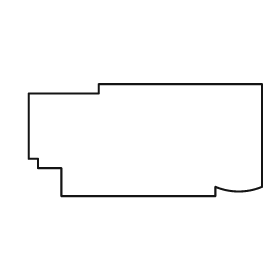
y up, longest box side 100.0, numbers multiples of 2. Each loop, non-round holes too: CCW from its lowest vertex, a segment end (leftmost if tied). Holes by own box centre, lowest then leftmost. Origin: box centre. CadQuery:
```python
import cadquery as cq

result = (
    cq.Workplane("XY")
    .moveTo(-36.0, -24.0)
    .lineTo(30.0, -24.0)
    .lineTo(30.0, -20.0)
    .threePointArc((40.0, -22.0), (50.0, -20.0))
    .lineTo(50.0, 24.0)
    .lineTo(-20.0, 24.0)
    .lineTo(-20.0, 20.0)
    .lineTo(-50.0, 20.0)
    .lineTo(-50.0, -8.0)
    .lineTo(-46.0, -8.0)
    .lineTo(-46.0, -12.0)
    .lineTo(-36.0, -12.0)
    .close()
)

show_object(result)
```